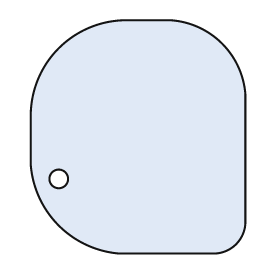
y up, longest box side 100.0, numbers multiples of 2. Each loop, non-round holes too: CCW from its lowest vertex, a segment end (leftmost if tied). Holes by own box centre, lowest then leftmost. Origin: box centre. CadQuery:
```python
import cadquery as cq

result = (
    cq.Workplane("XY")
    .moveTo(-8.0, -50.0)
    .lineTo(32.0, -50.0)
    .threePointArc((42.0, -46.0), (46.0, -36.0))
    .lineTo(46.0, 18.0)
    .threePointArc((36.0, 40.0), (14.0, 50.0))
    .lineTo(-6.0, 50.0)
    .threePointArc((-34.0, 38.0), (-46.0, 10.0))
    .lineTo(-46.0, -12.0)
    .threePointArc((-34.0, -38.0), (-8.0, -50.0))
    .close()
    .moveTo(-34.0, -18.0)
    .circle(4.0)
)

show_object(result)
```